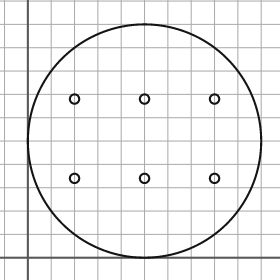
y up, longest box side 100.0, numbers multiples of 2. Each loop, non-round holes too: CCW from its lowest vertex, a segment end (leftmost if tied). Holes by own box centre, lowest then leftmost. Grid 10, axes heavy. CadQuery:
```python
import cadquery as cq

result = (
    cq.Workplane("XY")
    .moveTo(50.0, 50.0)
    .circle(50.0)
    .moveTo(20.0, 34.0)
    .circle(2.0)
    .moveTo(50.0, 34.0)
    .circle(2.0)
    .moveTo(80.0, 34.0)
    .circle(2.0)
    .moveTo(20.0, 68.0)
    .circle(2.0)
    .moveTo(50.0, 68.0)
    .circle(2.0)
    .moveTo(80.0, 68.0)
    .circle(2.0)
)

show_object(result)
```